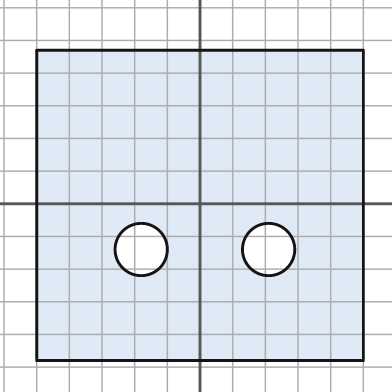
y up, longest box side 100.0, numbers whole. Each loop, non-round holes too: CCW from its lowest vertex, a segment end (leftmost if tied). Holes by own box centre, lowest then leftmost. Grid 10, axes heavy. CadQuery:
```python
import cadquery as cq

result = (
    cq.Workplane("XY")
    .moveTo(-50.0, -48.0)
    .lineTo(50.0, -48.0)
    .lineTo(50.0, 47.0)
    .lineTo(-50.0, 47.0)
    .close()
    .moveTo(-18.0, -14.0)
    .circle(8.0)
    .moveTo(21.0, -14.0)
    .circle(8.0)
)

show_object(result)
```